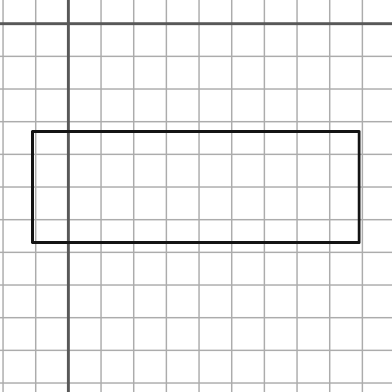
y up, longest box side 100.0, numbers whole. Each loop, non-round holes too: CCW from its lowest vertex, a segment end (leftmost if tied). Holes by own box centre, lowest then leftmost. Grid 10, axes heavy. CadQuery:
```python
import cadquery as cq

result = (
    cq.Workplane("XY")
    .moveTo(-11.0, -67.0)
    .lineTo(89.0, -67.0)
    .lineTo(89.0, -33.0)
    .lineTo(-11.0, -33.0)
    .close()
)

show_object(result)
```